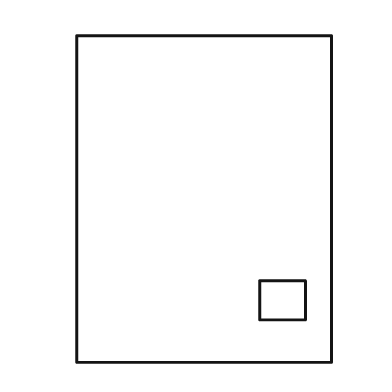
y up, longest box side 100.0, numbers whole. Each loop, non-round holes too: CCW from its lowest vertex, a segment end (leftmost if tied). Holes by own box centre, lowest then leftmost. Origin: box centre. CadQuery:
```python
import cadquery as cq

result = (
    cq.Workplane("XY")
    .moveTo(-39.0, -50.0)
    .lineTo(39.0, -50.0)
    .lineTo(39.0, 50.0)
    .lineTo(-39.0, 50.0)
    .close()
    .moveTo(17.0, -37.0)
    .lineTo(31.0, -37.0)
    .lineTo(31.0, -25.0)
    .lineTo(17.0, -25.0)
    .close()
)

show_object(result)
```